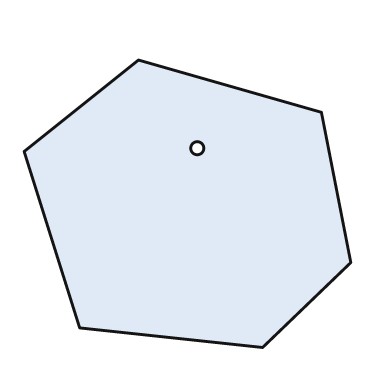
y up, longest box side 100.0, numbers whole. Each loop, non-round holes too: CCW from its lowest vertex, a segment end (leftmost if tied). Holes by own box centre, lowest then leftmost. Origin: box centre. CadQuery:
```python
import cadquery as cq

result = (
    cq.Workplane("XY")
    .moveTo(23.0, -44.0)
    .lineTo(50.0, -18.0)
    .lineTo(41.0, 28.0)
    .lineTo(-15.0, 44.0)
    .lineTo(-50.0, 16.0)
    .lineTo(-33.0, -38.0)
    .close()
    .moveTo(3.0, 17.0)
    .circle(2.0)
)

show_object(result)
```